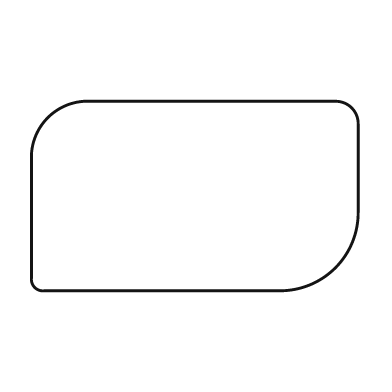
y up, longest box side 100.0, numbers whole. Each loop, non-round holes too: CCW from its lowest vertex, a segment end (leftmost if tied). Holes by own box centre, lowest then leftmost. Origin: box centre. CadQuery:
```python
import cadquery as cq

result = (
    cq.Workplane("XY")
    .moveTo(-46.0, -29.0)
    .lineTo(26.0, -29.0)
    .threePointArc((43.0, -22.0), (50.0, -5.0))
    .lineTo(50.0, 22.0)
    .threePointArc((48.0, 27.0), (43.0, 29.0))
    .lineTo(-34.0, 29.0)
    .threePointArc((-45.0, 24.0), (-50.0, 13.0))
    .lineTo(-50.0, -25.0)
    .threePointArc((-49.0, -28.0), (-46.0, -29.0))
    .close()
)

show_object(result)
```